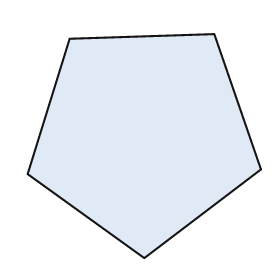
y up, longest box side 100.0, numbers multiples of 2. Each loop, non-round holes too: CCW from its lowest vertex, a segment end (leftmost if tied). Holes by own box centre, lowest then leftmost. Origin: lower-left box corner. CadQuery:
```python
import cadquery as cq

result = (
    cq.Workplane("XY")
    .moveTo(50.0, 0.0)
    .lineTo(100.0, 38.0)
    .lineTo(80.0, 96.0)
    .lineTo(18.0, 94.0)
    .lineTo(0.0, 36.0)
    .close()
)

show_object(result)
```